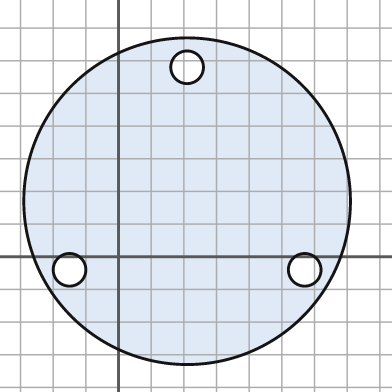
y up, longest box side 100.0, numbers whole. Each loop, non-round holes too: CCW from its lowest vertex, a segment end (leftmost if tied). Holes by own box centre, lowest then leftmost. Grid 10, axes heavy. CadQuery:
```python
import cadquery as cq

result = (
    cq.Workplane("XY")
    .moveTo(21.0, 17.0)
    .circle(50.0)
    .moveTo(-15.0, -4.0)
    .circle(5.0)
    .moveTo(57.0, -4.0)
    .circle(5.0)
    .moveTo(21.0, 58.0)
    .circle(5.0)
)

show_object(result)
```